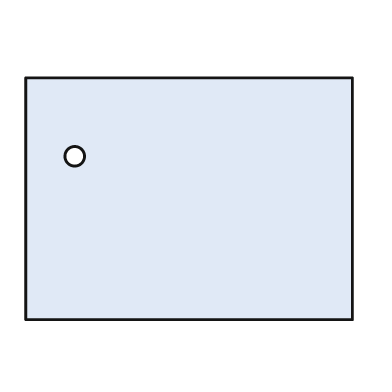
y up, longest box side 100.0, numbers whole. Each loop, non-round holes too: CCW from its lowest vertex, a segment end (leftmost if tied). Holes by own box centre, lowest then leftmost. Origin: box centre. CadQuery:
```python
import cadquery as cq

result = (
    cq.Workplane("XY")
    .moveTo(-50.0, -37.0)
    .lineTo(50.0, -37.0)
    .lineTo(50.0, 37.0)
    .lineTo(-50.0, 37.0)
    .close()
    .moveTo(-35.0, 13.0)
    .circle(3.0)
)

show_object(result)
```